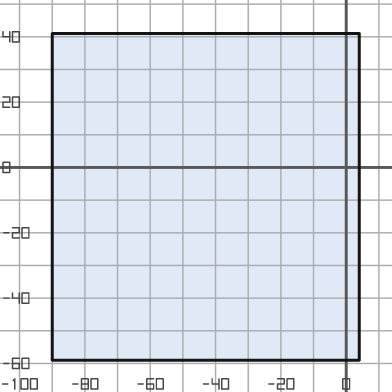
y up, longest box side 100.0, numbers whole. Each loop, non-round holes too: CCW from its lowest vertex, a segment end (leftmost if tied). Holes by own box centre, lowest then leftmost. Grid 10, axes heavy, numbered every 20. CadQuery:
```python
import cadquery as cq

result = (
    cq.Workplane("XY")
    .moveTo(-90.0, -59.0)
    .lineTo(4.0, -59.0)
    .lineTo(4.0, 41.0)
    .lineTo(-90.0, 41.0)
    .close()
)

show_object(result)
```